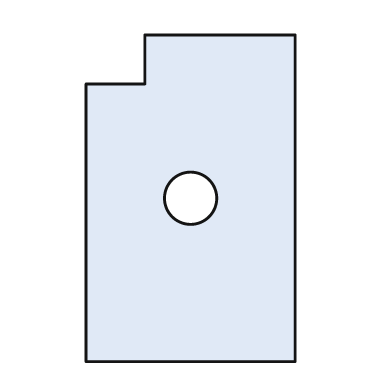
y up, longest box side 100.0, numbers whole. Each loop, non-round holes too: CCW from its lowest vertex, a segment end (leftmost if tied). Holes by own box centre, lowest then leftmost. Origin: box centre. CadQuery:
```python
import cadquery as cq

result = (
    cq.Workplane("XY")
    .moveTo(-32.0, -50.0)
    .lineTo(32.0, -50.0)
    .lineTo(32.0, 50.0)
    .lineTo(-14.0, 50.0)
    .lineTo(-14.0, 35.0)
    .lineTo(-32.0, 35.0)
    .close()
    .moveTo(0.0, 0.0)
    .circle(8.0)
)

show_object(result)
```